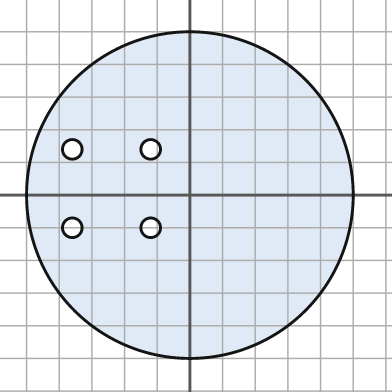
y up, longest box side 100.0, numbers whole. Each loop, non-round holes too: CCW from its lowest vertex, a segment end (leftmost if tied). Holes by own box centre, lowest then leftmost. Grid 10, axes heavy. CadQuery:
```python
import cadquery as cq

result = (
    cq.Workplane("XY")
    .moveTo(0.0, 0.0)
    .circle(50.0)
    .moveTo(-36.0, -10.0)
    .circle(3.0)
    .moveTo(-12.0, -10.0)
    .circle(3.0)
    .moveTo(-36.0, 14.0)
    .circle(3.0)
    .moveTo(-12.0, 14.0)
    .circle(3.0)
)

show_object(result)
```